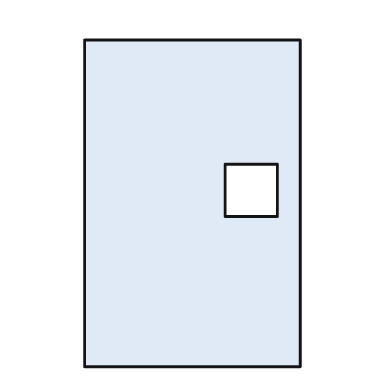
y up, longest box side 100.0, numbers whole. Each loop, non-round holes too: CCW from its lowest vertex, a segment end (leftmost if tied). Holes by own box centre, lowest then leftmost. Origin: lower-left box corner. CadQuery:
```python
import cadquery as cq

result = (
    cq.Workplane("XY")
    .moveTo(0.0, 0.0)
    .lineTo(66.0, 0.0)
    .lineTo(66.0, 100.0)
    .lineTo(0.0, 100.0)
    .close()
    .moveTo(43.0, 46.0)
    .lineTo(59.0, 46.0)
    .lineTo(59.0, 62.0)
    .lineTo(43.0, 62.0)
    .close()
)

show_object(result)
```